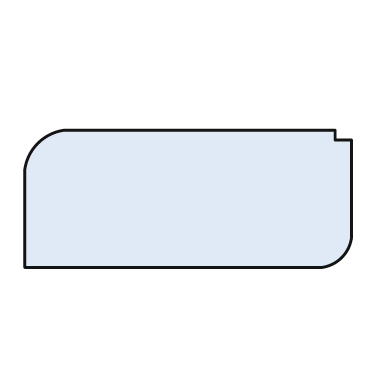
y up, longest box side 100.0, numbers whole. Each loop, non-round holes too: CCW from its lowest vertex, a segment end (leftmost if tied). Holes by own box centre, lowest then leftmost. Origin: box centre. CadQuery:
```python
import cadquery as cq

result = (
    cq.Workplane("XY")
    .moveTo(-50.0, -21.0)
    .lineTo(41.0, -21.0)
    .threePointArc((47.0, -18.0), (50.0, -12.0))
    .lineTo(50.0, 18.0)
    .lineTo(45.0, 18.0)
    .lineTo(45.0, 21.0)
    .lineTo(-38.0, 21.0)
    .threePointArc((-46.0, 17.0), (-50.0, 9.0))
    .close()
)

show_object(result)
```